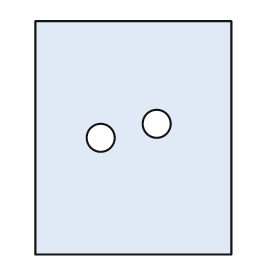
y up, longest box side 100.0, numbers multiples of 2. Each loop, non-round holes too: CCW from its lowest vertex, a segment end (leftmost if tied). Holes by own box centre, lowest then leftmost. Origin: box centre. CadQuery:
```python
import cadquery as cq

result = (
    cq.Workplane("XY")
    .moveTo(-42.0, -50.0)
    .lineTo(42.0, -50.0)
    .lineTo(42.0, 50.0)
    .lineTo(-42.0, 50.0)
    .close()
    .moveTo(-14.0, 0.0)
    .circle(6.0)
    .moveTo(10.0, 6.0)
    .circle(6.0)
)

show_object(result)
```